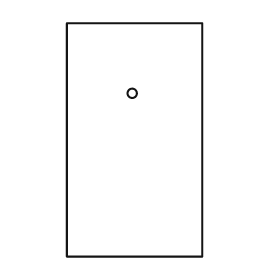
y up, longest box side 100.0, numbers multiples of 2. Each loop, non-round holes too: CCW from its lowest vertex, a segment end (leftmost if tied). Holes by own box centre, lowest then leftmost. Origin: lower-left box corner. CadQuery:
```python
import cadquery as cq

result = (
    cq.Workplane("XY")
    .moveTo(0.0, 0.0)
    .lineTo(58.0, 0.0)
    .lineTo(58.0, 100.0)
    .lineTo(0.0, 100.0)
    .close()
    .moveTo(28.0, 70.0)
    .circle(2.0)
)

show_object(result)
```